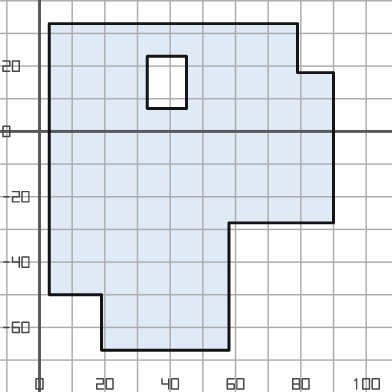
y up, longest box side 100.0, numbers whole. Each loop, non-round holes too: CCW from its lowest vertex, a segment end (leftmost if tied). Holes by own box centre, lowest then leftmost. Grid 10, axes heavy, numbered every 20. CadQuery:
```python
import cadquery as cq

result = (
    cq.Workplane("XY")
    .moveTo(19.0, -67.0)
    .lineTo(58.0, -67.0)
    .lineTo(58.0, -28.0)
    .lineTo(90.0, -28.0)
    .lineTo(90.0, 18.0)
    .lineTo(79.0, 18.0)
    .lineTo(79.0, 33.0)
    .lineTo(3.0, 33.0)
    .lineTo(3.0, -50.0)
    .lineTo(19.0, -50.0)
    .close()
    .moveTo(33.0, 7.0)
    .lineTo(45.0, 7.0)
    .lineTo(45.0, 23.0)
    .lineTo(33.0, 23.0)
    .close()
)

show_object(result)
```